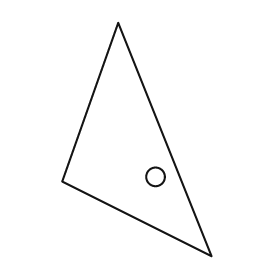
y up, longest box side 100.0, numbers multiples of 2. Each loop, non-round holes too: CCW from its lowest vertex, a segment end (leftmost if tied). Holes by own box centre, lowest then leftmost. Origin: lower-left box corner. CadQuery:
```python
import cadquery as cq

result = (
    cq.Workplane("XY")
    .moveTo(64.0, 0.0)
    .lineTo(24.0, 100.0)
    .lineTo(0.0, 32.0)
    .close()
    .moveTo(40.0, 34.0)
    .circle(4.0)
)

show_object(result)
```